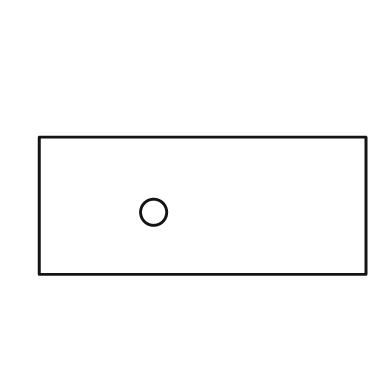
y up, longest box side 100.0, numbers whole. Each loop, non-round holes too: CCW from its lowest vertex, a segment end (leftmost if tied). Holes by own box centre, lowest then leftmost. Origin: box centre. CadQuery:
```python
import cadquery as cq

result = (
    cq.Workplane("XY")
    .moveTo(-50.0, -21.0)
    .lineTo(50.0, -21.0)
    .lineTo(50.0, 21.0)
    .lineTo(-50.0, 21.0)
    .close()
    .moveTo(-15.0, -2.0)
    .circle(4.0)
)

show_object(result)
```